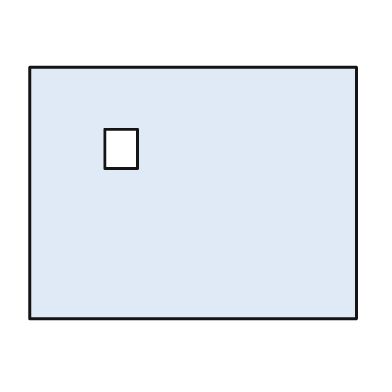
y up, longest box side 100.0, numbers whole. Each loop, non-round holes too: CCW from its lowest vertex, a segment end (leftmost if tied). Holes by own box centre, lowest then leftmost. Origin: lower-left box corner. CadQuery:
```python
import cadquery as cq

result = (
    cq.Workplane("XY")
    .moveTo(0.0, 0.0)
    .lineTo(100.0, 0.0)
    .lineTo(100.0, 77.0)
    .lineTo(0.0, 77.0)
    .close()
    .moveTo(23.0, 46.0)
    .lineTo(33.0, 46.0)
    .lineTo(33.0, 58.0)
    .lineTo(23.0, 58.0)
    .close()
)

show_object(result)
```